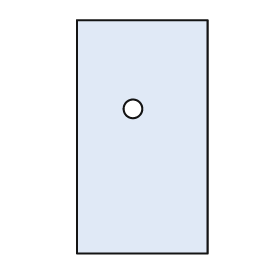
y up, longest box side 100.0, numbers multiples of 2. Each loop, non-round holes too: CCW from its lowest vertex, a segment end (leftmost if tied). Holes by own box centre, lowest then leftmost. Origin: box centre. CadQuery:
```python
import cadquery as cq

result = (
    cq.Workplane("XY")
    .moveTo(-28.0, -50.0)
    .lineTo(28.0, -50.0)
    .lineTo(28.0, 50.0)
    .lineTo(-28.0, 50.0)
    .close()
    .moveTo(-4.0, 12.0)
    .circle(4.0)
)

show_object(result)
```